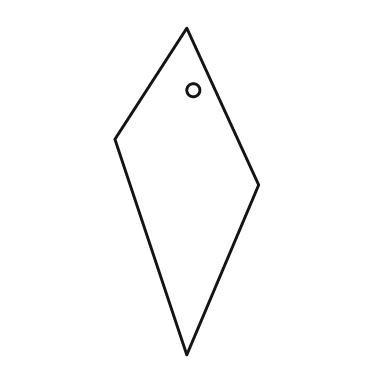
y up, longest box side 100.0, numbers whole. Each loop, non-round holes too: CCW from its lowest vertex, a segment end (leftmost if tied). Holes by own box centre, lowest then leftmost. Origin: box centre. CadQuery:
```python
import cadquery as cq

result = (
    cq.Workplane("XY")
    .moveTo(0.0, -50.0)
    .lineTo(22.0, 2.0)
    .lineTo(0.0, 50.0)
    .lineTo(-22.0, 16.0)
    .close()
    .moveTo(2.0, 31.0)
    .circle(2.0)
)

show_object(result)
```